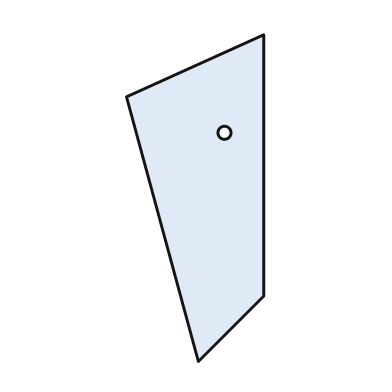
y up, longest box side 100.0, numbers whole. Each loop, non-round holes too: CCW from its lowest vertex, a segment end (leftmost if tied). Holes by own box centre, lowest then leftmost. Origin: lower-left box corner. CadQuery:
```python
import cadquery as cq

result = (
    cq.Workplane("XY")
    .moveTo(22.0, 0.0)
    .lineTo(42.0, 20.0)
    .lineTo(42.0, 100.0)
    .lineTo(0.0, 81.0)
    .close()
    .moveTo(30.0, 70.0)
    .circle(2.0)
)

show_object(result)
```